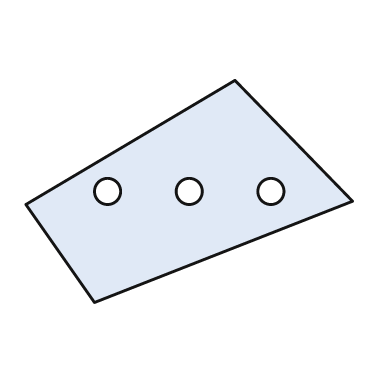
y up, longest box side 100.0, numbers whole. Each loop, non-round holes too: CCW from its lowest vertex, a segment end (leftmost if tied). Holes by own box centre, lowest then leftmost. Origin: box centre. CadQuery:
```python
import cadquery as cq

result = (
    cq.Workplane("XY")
    .moveTo(-29.0, -34.0)
    .lineTo(50.0, -3.0)
    .lineTo(14.0, 34.0)
    .lineTo(-50.0, -4.0)
    .close()
    .moveTo(-25.0, 0.0)
    .circle(4.0)
    .moveTo(0.0, 0.0)
    .circle(4.0)
    .moveTo(25.0, 0.0)
    .circle(4.0)
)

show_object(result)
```